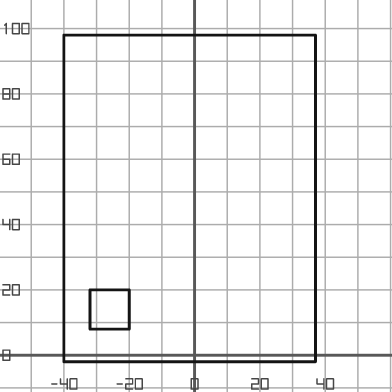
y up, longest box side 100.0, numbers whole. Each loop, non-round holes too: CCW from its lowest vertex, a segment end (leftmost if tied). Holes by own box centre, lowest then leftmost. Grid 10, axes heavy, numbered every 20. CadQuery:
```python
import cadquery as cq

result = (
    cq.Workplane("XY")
    .moveTo(-40.0, -2.0)
    .lineTo(37.0, -2.0)
    .lineTo(37.0, 98.0)
    .lineTo(-40.0, 98.0)
    .close()
    .moveTo(-32.0, 8.0)
    .lineTo(-20.0, 8.0)
    .lineTo(-20.0, 20.0)
    .lineTo(-32.0, 20.0)
    .close()
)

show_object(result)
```